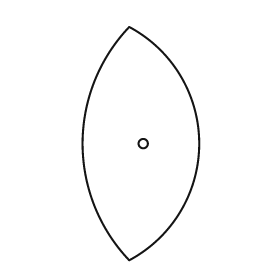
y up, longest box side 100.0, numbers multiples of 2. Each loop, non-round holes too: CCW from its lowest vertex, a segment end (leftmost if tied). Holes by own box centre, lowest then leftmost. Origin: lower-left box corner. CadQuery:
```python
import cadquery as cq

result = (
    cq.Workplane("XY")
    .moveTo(20.0, 0.0)
    .threePointArc((50.0, 50.0), (20.0, 100.0))
    .threePointArc((0.0, 50.0), (20.0, 0.0))
    .close()
    .moveTo(26.0, 50.0)
    .circle(2.0)
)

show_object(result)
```